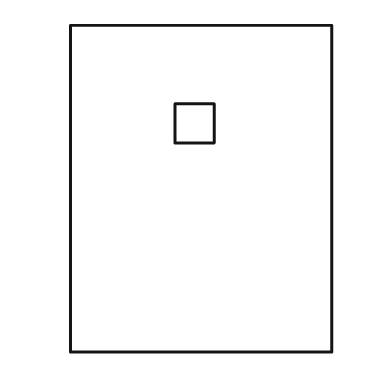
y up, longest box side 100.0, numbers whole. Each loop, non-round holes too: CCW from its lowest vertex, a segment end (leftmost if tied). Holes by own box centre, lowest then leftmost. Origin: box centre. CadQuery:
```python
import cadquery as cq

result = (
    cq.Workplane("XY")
    .moveTo(-40.0, -50.0)
    .lineTo(40.0, -50.0)
    .lineTo(40.0, 50.0)
    .lineTo(-40.0, 50.0)
    .close()
    .moveTo(-8.0, 14.0)
    .lineTo(4.0, 14.0)
    .lineTo(4.0, 26.0)
    .lineTo(-8.0, 26.0)
    .close()
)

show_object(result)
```